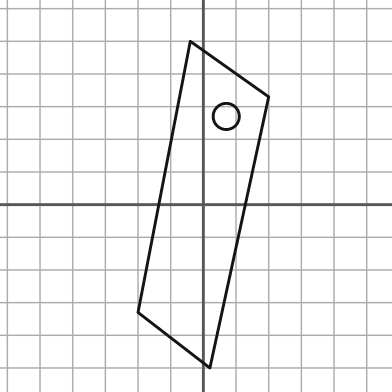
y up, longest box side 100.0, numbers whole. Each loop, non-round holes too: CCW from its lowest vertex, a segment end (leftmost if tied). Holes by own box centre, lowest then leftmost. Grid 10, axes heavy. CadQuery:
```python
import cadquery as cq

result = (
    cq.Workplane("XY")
    .moveTo(2.0, -50.0)
    .lineTo(20.0, 33.0)
    .lineTo(-4.0, 50.0)
    .lineTo(-20.0, -33.0)
    .close()
    .moveTo(7.0, 27.0)
    .circle(4.0)
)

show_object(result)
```